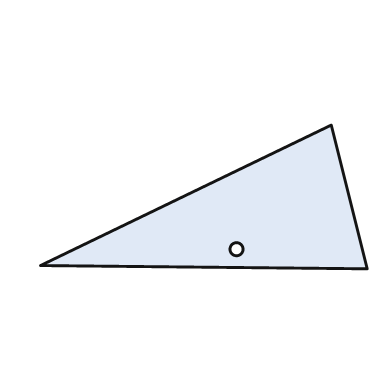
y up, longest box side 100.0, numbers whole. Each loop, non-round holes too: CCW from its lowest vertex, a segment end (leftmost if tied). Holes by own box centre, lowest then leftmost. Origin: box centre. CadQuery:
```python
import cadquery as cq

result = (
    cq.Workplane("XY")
    .moveTo(50.0, -22.0)
    .lineTo(39.0, 22.0)
    .lineTo(-50.0, -21.0)
    .close()
    .moveTo(10.0, -16.0)
    .circle(2.0)
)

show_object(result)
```